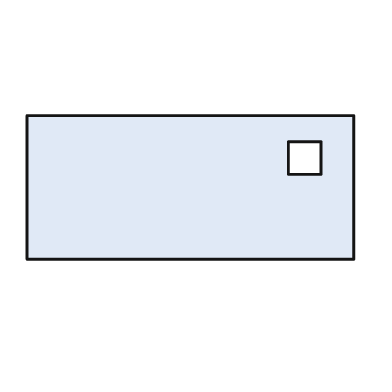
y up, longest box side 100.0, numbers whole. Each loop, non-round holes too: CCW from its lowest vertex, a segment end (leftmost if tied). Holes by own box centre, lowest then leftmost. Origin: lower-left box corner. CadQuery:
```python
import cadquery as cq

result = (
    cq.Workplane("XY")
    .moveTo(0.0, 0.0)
    .lineTo(100.0, 0.0)
    .lineTo(100.0, 44.0)
    .lineTo(0.0, 44.0)
    .close()
    .moveTo(80.0, 26.0)
    .lineTo(90.0, 26.0)
    .lineTo(90.0, 36.0)
    .lineTo(80.0, 36.0)
    .close()
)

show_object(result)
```